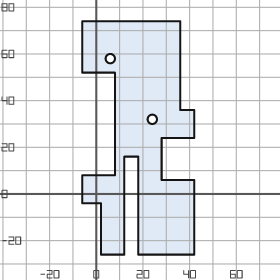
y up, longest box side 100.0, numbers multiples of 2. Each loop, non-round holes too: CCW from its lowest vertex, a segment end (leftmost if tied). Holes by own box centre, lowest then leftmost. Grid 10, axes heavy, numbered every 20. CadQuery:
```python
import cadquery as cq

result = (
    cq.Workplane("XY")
    .moveTo(2.0, -26.0)
    .lineTo(12.0, -26.0)
    .lineTo(12.0, 16.0)
    .lineTo(18.0, 16.0)
    .lineTo(18.0, -26.0)
    .lineTo(42.0, -26.0)
    .lineTo(42.0, 6.0)
    .lineTo(28.0, 6.0)
    .lineTo(28.0, 24.0)
    .lineTo(42.0, 24.0)
    .lineTo(42.0, 36.0)
    .lineTo(36.0, 36.0)
    .lineTo(36.0, 74.0)
    .lineTo(-6.0, 74.0)
    .lineTo(-6.0, 52.0)
    .lineTo(8.0, 52.0)
    .lineTo(8.0, 8.0)
    .lineTo(-6.0, 8.0)
    .lineTo(-6.0, -4.0)
    .lineTo(2.0, -4.0)
    .close()
    .moveTo(24.0, 32.0)
    .circle(2.0)
    .moveTo(6.0, 58.0)
    .circle(2.0)
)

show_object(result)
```